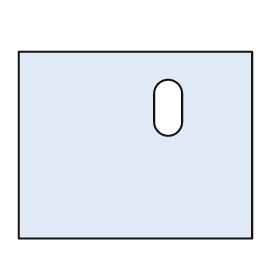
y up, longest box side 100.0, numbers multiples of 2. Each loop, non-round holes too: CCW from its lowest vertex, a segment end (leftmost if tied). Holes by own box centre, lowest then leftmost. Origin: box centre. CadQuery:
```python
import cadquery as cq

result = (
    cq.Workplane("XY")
    .moveTo(-50.0, -40.0)
    .lineTo(50.0, -40.0)
    .lineTo(50.0, 40.0)
    .lineTo(-50.0, 40.0)
    .close()
    .moveTo(8.0, 10.0)
    .threePointArc((14.0, 4.0), (20.0, 10.0))
    .lineTo(20.0, 22.0)
    .threePointArc((14.0, 28.0), (8.0, 22.0))
    .close()
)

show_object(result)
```